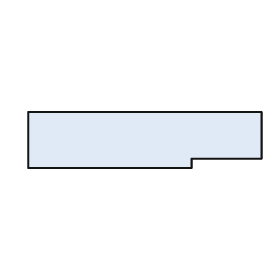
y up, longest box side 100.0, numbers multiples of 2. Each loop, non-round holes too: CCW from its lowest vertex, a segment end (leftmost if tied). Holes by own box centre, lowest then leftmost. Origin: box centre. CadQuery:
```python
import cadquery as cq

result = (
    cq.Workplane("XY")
    .moveTo(-50.0, -12.0)
    .lineTo(20.0, -12.0)
    .lineTo(20.0, -8.0)
    .lineTo(50.0, -8.0)
    .lineTo(50.0, 12.0)
    .lineTo(-50.0, 12.0)
    .close()
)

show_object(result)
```